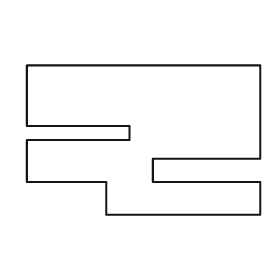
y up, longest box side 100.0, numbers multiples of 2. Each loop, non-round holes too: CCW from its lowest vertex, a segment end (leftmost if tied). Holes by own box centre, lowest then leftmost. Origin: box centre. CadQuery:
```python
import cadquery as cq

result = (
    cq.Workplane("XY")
    .moveTo(-16.0, -32.0)
    .lineTo(50.0, -32.0)
    .lineTo(50.0, -18.0)
    .lineTo(4.0, -18.0)
    .lineTo(4.0, -8.0)
    .lineTo(50.0, -8.0)
    .lineTo(50.0, 32.0)
    .lineTo(-50.0, 32.0)
    .lineTo(-50.0, 6.0)
    .lineTo(-6.0, 6.0)
    .lineTo(-6.0, 0.0)
    .lineTo(-50.0, 0.0)
    .lineTo(-50.0, -18.0)
    .lineTo(-16.0, -18.0)
    .close()
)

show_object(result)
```